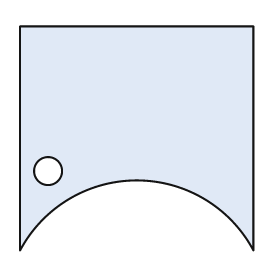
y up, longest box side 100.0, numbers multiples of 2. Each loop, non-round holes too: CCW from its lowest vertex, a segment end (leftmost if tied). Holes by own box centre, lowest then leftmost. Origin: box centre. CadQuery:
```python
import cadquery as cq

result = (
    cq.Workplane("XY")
    .moveTo(-50.0, -48.0)
    .threePointArc((0.0, -18.0), (50.0, -48.0))
    .lineTo(50.0, 48.0)
    .lineTo(-50.0, 48.0)
    .close()
    .moveTo(-38.0, -14.0)
    .circle(6.0)
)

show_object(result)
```